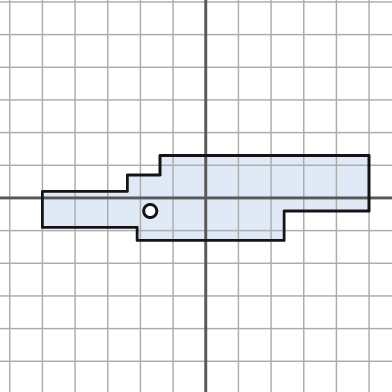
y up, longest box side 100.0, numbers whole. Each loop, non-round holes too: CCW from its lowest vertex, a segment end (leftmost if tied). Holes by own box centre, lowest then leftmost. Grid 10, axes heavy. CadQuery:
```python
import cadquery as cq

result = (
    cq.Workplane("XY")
    .moveTo(-21.0, -13.0)
    .lineTo(24.0, -13.0)
    .lineTo(24.0, -4.0)
    .lineTo(50.0, -4.0)
    .lineTo(50.0, 13.0)
    .lineTo(-14.0, 13.0)
    .lineTo(-14.0, 7.0)
    .lineTo(-24.0, 7.0)
    .lineTo(-24.0, 2.0)
    .lineTo(-50.0, 2.0)
    .lineTo(-50.0, -9.0)
    .lineTo(-21.0, -9.0)
    .close()
    .moveTo(-17.0, -4.0)
    .circle(2.0)
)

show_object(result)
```